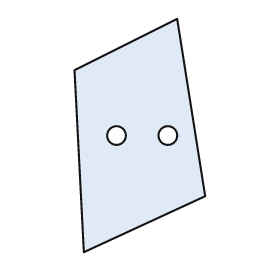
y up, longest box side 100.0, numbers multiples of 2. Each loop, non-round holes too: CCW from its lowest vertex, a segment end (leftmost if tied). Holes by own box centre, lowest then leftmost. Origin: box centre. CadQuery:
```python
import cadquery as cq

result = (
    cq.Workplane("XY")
    .moveTo(-24.0, -50.0)
    .lineTo(28.0, -26.0)
    .lineTo(16.0, 50.0)
    .lineTo(-28.0, 28.0)
    .close()
    .moveTo(-10.0, 0.0)
    .circle(4.0)
    .moveTo(12.0, 0.0)
    .circle(4.0)
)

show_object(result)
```